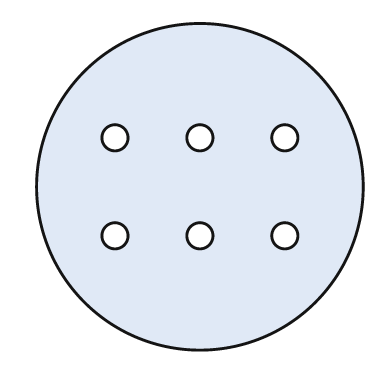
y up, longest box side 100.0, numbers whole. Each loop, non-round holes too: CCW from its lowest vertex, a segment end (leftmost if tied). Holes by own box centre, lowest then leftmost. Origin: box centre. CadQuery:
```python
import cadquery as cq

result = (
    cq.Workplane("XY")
    .moveTo(0.0, 0.0)
    .circle(50.0)
    .moveTo(-26.0, -15.0)
    .circle(4.0)
    .moveTo(0.0, -15.0)
    .circle(4.0)
    .moveTo(26.0, -15.0)
    .circle(4.0)
    .moveTo(-26.0, 15.0)
    .circle(4.0)
    .moveTo(0.0, 15.0)
    .circle(4.0)
    .moveTo(26.0, 15.0)
    .circle(4.0)
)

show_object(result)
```